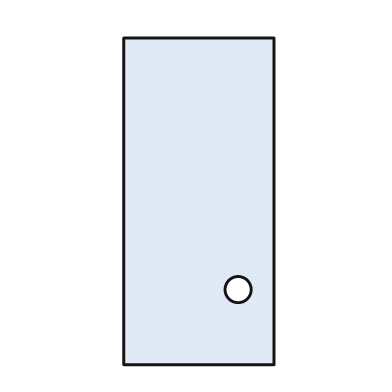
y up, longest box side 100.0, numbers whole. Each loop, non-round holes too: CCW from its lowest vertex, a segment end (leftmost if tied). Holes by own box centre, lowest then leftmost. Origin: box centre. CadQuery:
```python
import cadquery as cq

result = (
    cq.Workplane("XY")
    .moveTo(-23.0, -50.0)
    .lineTo(23.0, -50.0)
    .lineTo(23.0, 50.0)
    .lineTo(-23.0, 50.0)
    .close()
    .moveTo(12.0, -27.0)
    .circle(4.0)
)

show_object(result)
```